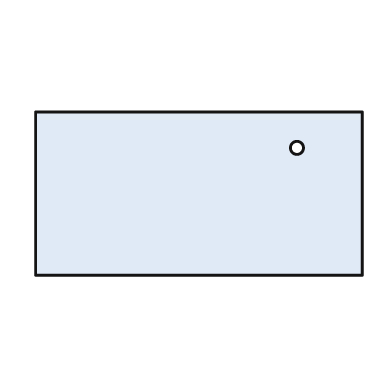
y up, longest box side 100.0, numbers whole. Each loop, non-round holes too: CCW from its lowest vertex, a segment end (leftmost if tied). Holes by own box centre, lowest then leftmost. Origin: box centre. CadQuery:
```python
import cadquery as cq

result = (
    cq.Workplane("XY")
    .moveTo(-50.0, -25.0)
    .lineTo(50.0, -25.0)
    .lineTo(50.0, 25.0)
    .lineTo(-50.0, 25.0)
    .close()
    .moveTo(30.0, 14.0)
    .circle(2.0)
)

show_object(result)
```